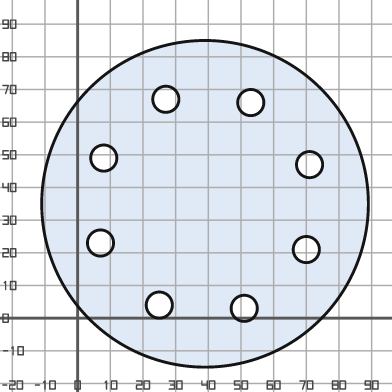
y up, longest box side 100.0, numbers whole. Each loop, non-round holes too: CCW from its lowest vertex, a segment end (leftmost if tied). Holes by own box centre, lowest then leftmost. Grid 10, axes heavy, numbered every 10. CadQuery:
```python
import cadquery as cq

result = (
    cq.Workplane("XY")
    .moveTo(39.0, 35.0)
    .circle(50.0)
    .moveTo(51.0, 3.0)
    .circle(4.0)
    .moveTo(25.0, 4.0)
    .circle(4.0)
    .moveTo(70.0, 21.0)
    .circle(4.0)
    .moveTo(7.0, 23.0)
    .circle(4.0)
    .moveTo(71.0, 47.0)
    .circle(4.0)
    .moveTo(8.0, 49.0)
    .circle(4.0)
    .moveTo(53.0, 66.0)
    .circle(4.0)
    .moveTo(27.0, 67.0)
    .circle(4.0)
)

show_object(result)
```